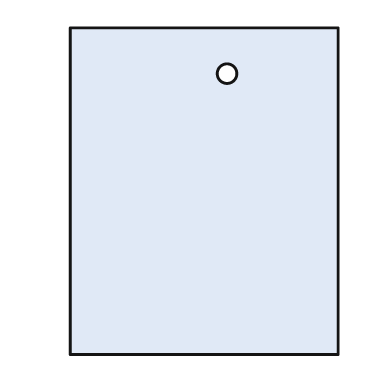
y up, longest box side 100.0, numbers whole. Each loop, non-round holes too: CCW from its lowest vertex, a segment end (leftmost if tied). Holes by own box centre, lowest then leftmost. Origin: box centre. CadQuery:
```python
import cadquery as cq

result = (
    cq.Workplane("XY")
    .moveTo(-41.0, -50.0)
    .lineTo(41.0, -50.0)
    .lineTo(41.0, 50.0)
    .lineTo(-41.0, 50.0)
    .close()
    .moveTo(7.0, 36.0)
    .circle(3.0)
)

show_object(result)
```